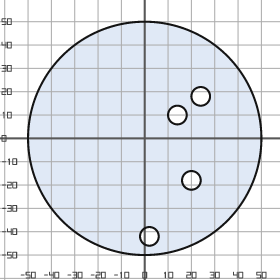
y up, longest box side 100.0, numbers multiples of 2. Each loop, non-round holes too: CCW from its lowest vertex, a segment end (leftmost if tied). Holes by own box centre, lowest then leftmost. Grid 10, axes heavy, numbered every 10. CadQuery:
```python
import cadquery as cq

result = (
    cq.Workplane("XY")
    .moveTo(0.0, 0.0)
    .circle(50.0)
    .moveTo(2.0, -42.0)
    .circle(4.0)
    .moveTo(20.0, -18.0)
    .circle(4.0)
    .moveTo(14.0, 10.0)
    .circle(4.0)
    .moveTo(24.0, 18.0)
    .circle(4.0)
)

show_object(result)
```